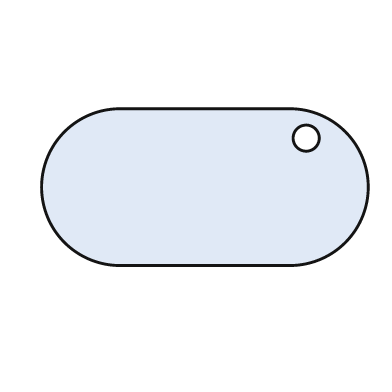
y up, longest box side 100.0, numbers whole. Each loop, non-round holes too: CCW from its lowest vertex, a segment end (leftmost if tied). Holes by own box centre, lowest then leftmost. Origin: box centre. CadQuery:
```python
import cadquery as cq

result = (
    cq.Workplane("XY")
    .moveTo(-26.0, -24.0)
    .lineTo(26.0, -24.0)
    .threePointArc((50.0, 0.0), (26.0, 24.0))
    .lineTo(-26.0, 24.0)
    .threePointArc((-50.0, 0.0), (-26.0, -24.0))
    .close()
    .moveTo(31.0, 15.0)
    .circle(4.0)
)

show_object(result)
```